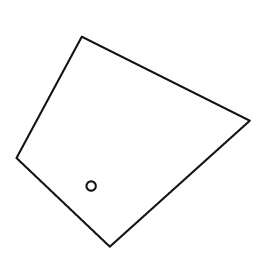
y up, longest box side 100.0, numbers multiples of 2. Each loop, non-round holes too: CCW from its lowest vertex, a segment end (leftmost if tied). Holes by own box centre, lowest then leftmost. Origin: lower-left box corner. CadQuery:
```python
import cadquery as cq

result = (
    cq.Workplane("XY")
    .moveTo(40.0, 0.0)
    .lineTo(100.0, 54.0)
    .lineTo(28.0, 90.0)
    .lineTo(0.0, 38.0)
    .close()
    .moveTo(32.0, 26.0)
    .circle(2.0)
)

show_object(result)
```